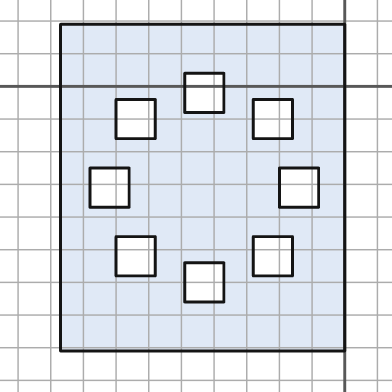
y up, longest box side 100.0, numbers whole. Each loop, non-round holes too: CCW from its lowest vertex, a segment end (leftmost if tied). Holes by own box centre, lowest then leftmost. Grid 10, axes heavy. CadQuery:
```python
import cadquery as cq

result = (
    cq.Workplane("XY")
    .moveTo(-87.0, -81.0)
    .lineTo(0.0, -81.0)
    .lineTo(0.0, 19.0)
    .lineTo(-87.0, 19.0)
    .close()
    .moveTo(-49.0, -66.0)
    .lineTo(-37.0, -66.0)
    .lineTo(-37.0, -54.0)
    .lineTo(-49.0, -54.0)
    .close()
    .moveTo(-70.0, -58.0)
    .lineTo(-58.0, -58.0)
    .lineTo(-58.0, -46.0)
    .lineTo(-70.0, -46.0)
    .close()
    .moveTo(-28.0, -58.0)
    .lineTo(-16.0, -58.0)
    .lineTo(-16.0, -46.0)
    .lineTo(-28.0, -46.0)
    .close()
    .moveTo(-78.0, -37.0)
    .lineTo(-66.0, -37.0)
    .lineTo(-66.0, -25.0)
    .lineTo(-78.0, -25.0)
    .close()
    .moveTo(-20.0, -37.0)
    .lineTo(-8.0, -37.0)
    .lineTo(-8.0, -25.0)
    .lineTo(-20.0, -25.0)
    .close()
    .moveTo(-70.0, -16.0)
    .lineTo(-58.0, -16.0)
    .lineTo(-58.0, -4.0)
    .lineTo(-70.0, -4.0)
    .close()
    .moveTo(-28.0, -16.0)
    .lineTo(-16.0, -16.0)
    .lineTo(-16.0, -4.0)
    .lineTo(-28.0, -4.0)
    .close()
    .moveTo(-49.0, -8.0)
    .lineTo(-37.0, -8.0)
    .lineTo(-37.0, 4.0)
    .lineTo(-49.0, 4.0)
    .close()
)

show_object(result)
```